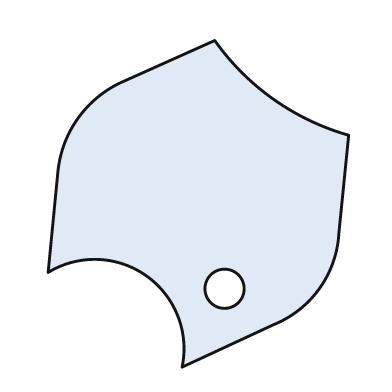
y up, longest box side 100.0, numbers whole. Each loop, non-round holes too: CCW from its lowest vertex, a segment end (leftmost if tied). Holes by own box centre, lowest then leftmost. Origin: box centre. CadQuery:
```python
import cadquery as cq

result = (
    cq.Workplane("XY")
    .moveTo(-5.0, -50.0)
    .lineTo(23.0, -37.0)
    .threePointArc((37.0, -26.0), (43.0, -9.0))
    .lineTo(46.0, 21.0)
    .threePointArc((23.0, 32.0), (5.0, 50.0))
    .lineTo(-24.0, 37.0)
    .threePointArc((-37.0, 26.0), (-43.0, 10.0))
    .lineTo(-46.0, -21.0)
    .threePointArc((-16.0, -22.0), (-5.0, -50.0))
    .close()
    .moveTo(8.0, -26.0)
    .circle(6.0)
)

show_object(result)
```